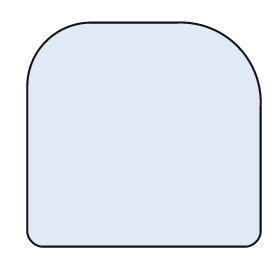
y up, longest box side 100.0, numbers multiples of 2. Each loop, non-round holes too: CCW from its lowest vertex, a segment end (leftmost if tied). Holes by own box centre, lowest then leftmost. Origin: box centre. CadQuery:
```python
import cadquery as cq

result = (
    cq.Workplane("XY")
    .moveTo(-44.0, -48.0)
    .lineTo(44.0, -48.0)
    .threePointArc((48.0, -46.0), (50.0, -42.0))
    .lineTo(50.0, 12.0)
    .threePointArc((40.0, 38.0), (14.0, 48.0))
    .lineTo(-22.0, 48.0)
    .threePointArc((-42.0, 40.0), (-50.0, 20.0))
    .lineTo(-50.0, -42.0)
    .threePointArc((-48.0, -46.0), (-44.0, -48.0))
    .close()
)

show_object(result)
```